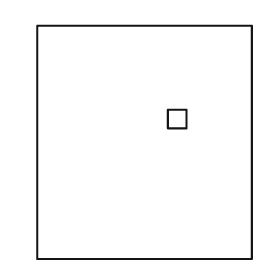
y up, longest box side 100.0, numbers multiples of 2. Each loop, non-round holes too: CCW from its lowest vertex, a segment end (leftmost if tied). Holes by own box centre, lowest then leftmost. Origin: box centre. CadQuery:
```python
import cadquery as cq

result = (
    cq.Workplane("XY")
    .moveTo(-46.0, -50.0)
    .lineTo(46.0, -50.0)
    .lineTo(46.0, 50.0)
    .lineTo(-46.0, 50.0)
    .close()
    .moveTo(10.0, 6.0)
    .lineTo(18.0, 6.0)
    .lineTo(18.0, 14.0)
    .lineTo(10.0, 14.0)
    .close()
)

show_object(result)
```